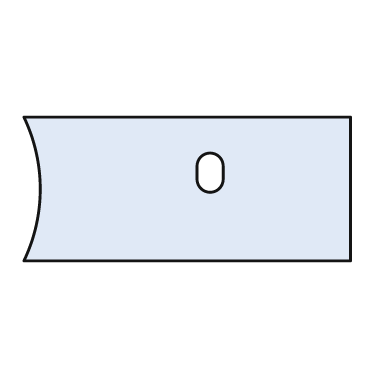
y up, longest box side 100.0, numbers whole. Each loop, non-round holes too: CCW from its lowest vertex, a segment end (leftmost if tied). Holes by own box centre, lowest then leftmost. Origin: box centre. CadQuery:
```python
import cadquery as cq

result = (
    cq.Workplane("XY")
    .moveTo(-50.0, -22.0)
    .lineTo(50.0, -22.0)
    .lineTo(50.0, 22.0)
    .lineTo(-50.0, 22.0)
    .threePointArc((-45.0, 0.0), (-50.0, -22.0))
    .close()
    .moveTo(3.0, 3.0)
    .threePointArc((7.0, -1.0), (11.0, 3.0))
    .lineTo(11.0, 7.0)
    .threePointArc((7.0, 11.0), (3.0, 7.0))
    .close()
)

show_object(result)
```